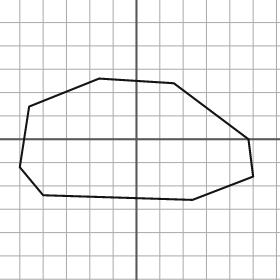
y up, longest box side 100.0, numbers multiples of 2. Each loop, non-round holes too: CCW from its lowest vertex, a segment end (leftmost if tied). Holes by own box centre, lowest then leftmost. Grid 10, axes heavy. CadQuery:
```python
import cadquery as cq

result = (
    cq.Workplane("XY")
    .moveTo(24.0, -26.0)
    .lineTo(50.0, -16.0)
    .lineTo(48.0, 0.0)
    .lineTo(16.0, 24.0)
    .lineTo(-16.0, 26.0)
    .lineTo(-46.0, 14.0)
    .lineTo(-50.0, -12.0)
    .lineTo(-40.0, -24.0)
    .close()
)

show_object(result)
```